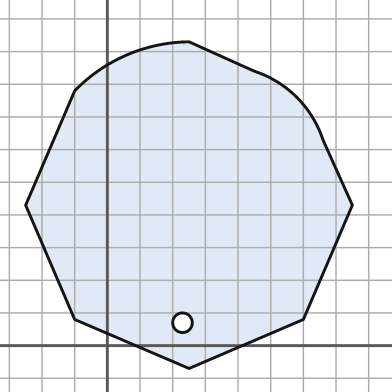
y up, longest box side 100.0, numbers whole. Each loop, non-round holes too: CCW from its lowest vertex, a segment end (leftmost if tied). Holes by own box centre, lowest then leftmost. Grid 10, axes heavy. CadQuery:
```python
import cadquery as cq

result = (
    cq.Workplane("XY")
    .moveTo(25.0, -7.0)
    .lineTo(60.0, 8.0)
    .lineTo(75.0, 43.0)
    .lineTo(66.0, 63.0)
    .threePointArc((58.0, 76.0), (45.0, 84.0))
    .lineTo(25.0, 93.0)
    .threePointArc((6.0, 89.0), (-10.0, 78.0))
    .lineTo(-25.0, 43.0)
    .lineTo(-10.0, 8.0)
    .close()
    .moveTo(23.0, 7.0)
    .circle(3.0)
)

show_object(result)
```